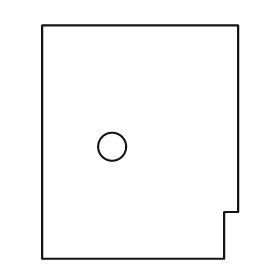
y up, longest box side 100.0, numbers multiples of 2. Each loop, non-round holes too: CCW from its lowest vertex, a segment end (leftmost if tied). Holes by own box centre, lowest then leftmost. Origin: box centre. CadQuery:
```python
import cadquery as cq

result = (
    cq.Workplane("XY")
    .moveTo(-42.0, -50.0)
    .lineTo(36.0, -50.0)
    .lineTo(36.0, -30.0)
    .lineTo(42.0, -30.0)
    .lineTo(42.0, 50.0)
    .lineTo(-42.0, 50.0)
    .close()
    .moveTo(-12.0, -2.0)
    .circle(6.0)
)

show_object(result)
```